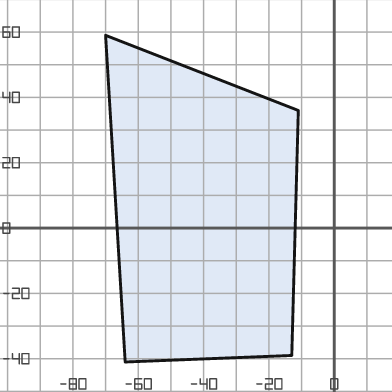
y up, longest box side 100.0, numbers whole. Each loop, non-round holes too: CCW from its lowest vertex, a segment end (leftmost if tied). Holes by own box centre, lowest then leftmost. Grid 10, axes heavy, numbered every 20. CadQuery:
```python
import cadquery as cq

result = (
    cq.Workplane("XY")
    .moveTo(-64.0, -41.0)
    .lineTo(-13.0, -39.0)
    .lineTo(-11.0, 36.0)
    .lineTo(-70.0, 59.0)
    .close()
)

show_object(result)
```